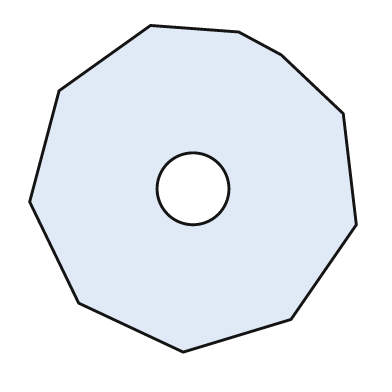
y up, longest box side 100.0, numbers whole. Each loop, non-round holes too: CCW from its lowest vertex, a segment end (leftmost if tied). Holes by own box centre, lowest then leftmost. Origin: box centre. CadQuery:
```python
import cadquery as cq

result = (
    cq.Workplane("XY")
    .moveTo(-3.0, -50.0)
    .lineTo(30.0, -40.0)
    .lineTo(50.0, -11.0)
    .lineTo(46.0, 23.0)
    .lineTo(27.0, 41.0)
    .lineTo(14.0, 48.0)
    .lineTo(-13.0, 50.0)
    .lineTo(-41.0, 30.0)
    .lineTo(-50.0, -4.0)
    .lineTo(-35.0, -35.0)
    .close()
    .moveTo(0.0, 0.0)
    .circle(11.0)
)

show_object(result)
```